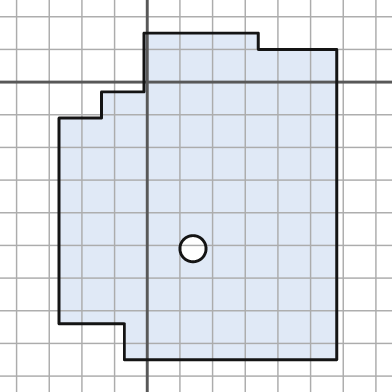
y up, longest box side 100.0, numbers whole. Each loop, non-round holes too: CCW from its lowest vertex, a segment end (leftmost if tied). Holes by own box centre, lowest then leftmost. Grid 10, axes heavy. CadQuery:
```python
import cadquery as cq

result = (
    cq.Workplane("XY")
    .moveTo(-7.0, -85.0)
    .lineTo(58.0, -85.0)
    .lineTo(58.0, 10.0)
    .lineTo(34.0, 10.0)
    .lineTo(34.0, 15.0)
    .lineTo(-1.0, 15.0)
    .lineTo(-1.0, -3.0)
    .lineTo(-14.0, -3.0)
    .lineTo(-14.0, -11.0)
    .lineTo(-27.0, -11.0)
    .lineTo(-27.0, -74.0)
    .lineTo(-7.0, -74.0)
    .close()
    .moveTo(14.0, -51.0)
    .circle(4.0)
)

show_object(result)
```